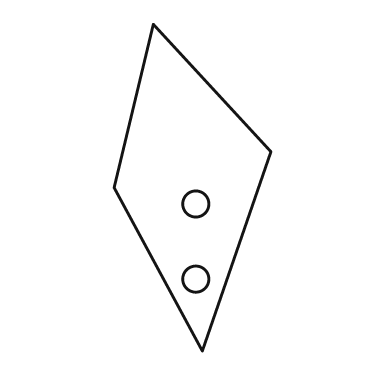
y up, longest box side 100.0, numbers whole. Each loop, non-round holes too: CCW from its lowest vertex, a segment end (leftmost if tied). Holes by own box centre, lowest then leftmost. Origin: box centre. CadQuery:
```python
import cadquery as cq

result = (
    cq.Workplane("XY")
    .moveTo(3.0, -50.0)
    .lineTo(24.0, 11.0)
    .lineTo(-12.0, 50.0)
    .lineTo(-24.0, 0.0)
    .close()
    .moveTo(1.0, -28.0)
    .circle(4.0)
    .moveTo(1.0, -5.0)
    .circle(4.0)
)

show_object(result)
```